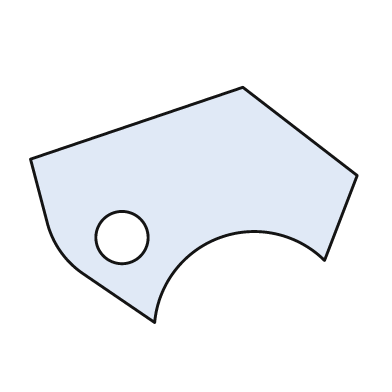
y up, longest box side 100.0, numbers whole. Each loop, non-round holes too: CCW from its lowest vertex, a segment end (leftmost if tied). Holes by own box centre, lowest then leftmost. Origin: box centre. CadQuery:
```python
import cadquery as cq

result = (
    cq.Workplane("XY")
    .moveTo(-12.0, -36.0)
    .threePointArc((8.0, -10.0), (40.0, -17.0))
    .lineTo(50.0, 9.0)
    .lineTo(15.0, 36.0)
    .lineTo(-50.0, 14.0)
    .lineTo(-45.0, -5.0)
    .threePointArc((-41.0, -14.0), (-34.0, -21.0))
    .close()
    .moveTo(-22.0, -10.0)
    .circle(8.0)
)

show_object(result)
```